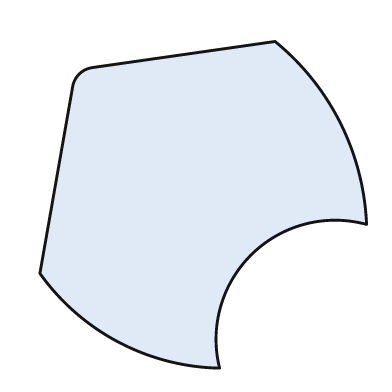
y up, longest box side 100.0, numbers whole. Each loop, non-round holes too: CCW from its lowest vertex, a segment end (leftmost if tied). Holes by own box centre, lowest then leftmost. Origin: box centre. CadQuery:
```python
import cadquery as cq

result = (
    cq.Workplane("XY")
    .moveTo(5.0, -50.0)
    .threePointArc((15.0, -15.0), (50.0, -6.0))
    .threePointArc((42.0, 25.0), (22.0, 50.0))
    .lineTo(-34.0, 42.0)
    .threePointArc((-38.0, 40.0), (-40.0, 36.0))
    .lineTo(-50.0, -21.0)
    .threePointArc((-26.0, -42.0), (5.0, -50.0))
    .close()
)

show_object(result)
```